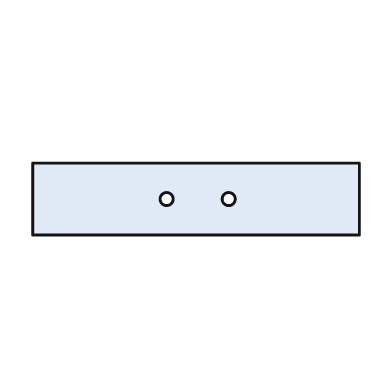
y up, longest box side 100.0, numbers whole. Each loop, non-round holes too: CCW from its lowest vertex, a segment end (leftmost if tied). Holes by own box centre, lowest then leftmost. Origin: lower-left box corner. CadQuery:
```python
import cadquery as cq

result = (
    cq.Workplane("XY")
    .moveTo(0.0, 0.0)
    .lineTo(100.0, 0.0)
    .lineTo(100.0, 22.0)
    .lineTo(0.0, 22.0)
    .close()
    .moveTo(41.0, 11.0)
    .circle(2.0)
    .moveTo(60.0, 11.0)
    .circle(2.0)
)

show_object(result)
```